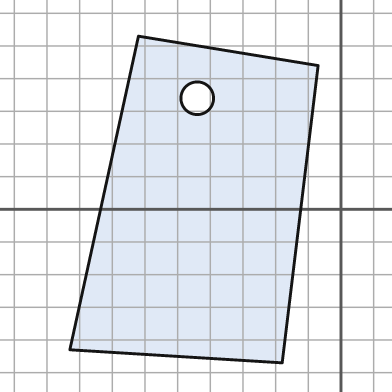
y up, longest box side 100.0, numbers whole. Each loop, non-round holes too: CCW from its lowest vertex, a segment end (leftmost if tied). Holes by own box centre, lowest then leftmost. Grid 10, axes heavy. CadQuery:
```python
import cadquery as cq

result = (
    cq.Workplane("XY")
    .moveTo(-18.0, -47.0)
    .lineTo(-7.0, 44.0)
    .lineTo(-62.0, 53.0)
    .lineTo(-83.0, -43.0)
    .close()
    .moveTo(-44.0, 34.0)
    .circle(5.0)
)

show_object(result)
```